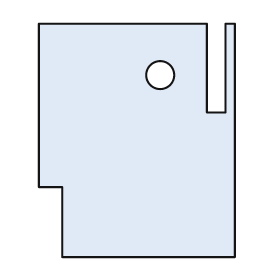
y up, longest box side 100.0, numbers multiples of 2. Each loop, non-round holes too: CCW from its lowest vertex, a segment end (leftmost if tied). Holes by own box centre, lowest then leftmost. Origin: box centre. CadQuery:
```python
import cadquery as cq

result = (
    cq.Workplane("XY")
    .moveTo(-32.0, -50.0)
    .lineTo(42.0, -50.0)
    .lineTo(42.0, 50.0)
    .lineTo(38.0, 50.0)
    .lineTo(38.0, 12.0)
    .lineTo(30.0, 12.0)
    .lineTo(30.0, 50.0)
    .lineTo(-42.0, 50.0)
    .lineTo(-42.0, -20.0)
    .lineTo(-32.0, -20.0)
    .close()
    .moveTo(10.0, 28.0)
    .circle(6.0)
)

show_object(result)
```